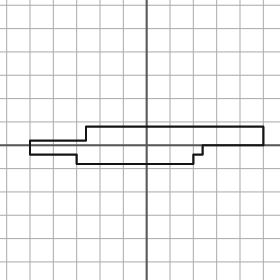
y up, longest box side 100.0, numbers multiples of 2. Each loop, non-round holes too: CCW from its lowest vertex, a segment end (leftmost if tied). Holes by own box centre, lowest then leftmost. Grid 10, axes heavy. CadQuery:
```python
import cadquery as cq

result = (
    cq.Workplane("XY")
    .moveTo(-30.0, -8.0)
    .lineTo(20.0, -8.0)
    .lineTo(20.0, -4.0)
    .lineTo(24.0, -4.0)
    .lineTo(24.0, 0.0)
    .lineTo(50.0, 0.0)
    .lineTo(50.0, 8.0)
    .lineTo(-26.0, 8.0)
    .lineTo(-26.0, 2.0)
    .lineTo(-50.0, 2.0)
    .lineTo(-50.0, -4.0)
    .lineTo(-30.0, -4.0)
    .close()
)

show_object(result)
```